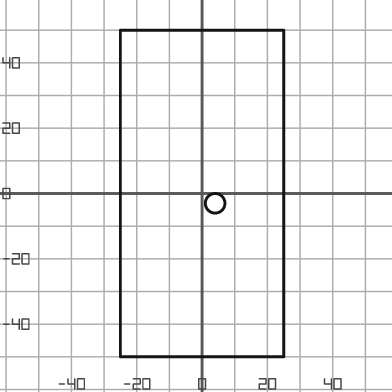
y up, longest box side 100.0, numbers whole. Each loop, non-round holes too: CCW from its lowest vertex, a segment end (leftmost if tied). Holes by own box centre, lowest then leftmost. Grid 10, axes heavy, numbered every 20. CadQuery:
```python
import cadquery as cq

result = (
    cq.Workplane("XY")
    .moveTo(-25.0, -50.0)
    .lineTo(25.0, -50.0)
    .lineTo(25.0, 50.0)
    .lineTo(-25.0, 50.0)
    .close()
    .moveTo(4.0, -3.0)
    .circle(3.0)
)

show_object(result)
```